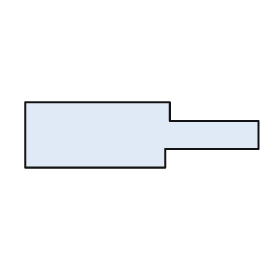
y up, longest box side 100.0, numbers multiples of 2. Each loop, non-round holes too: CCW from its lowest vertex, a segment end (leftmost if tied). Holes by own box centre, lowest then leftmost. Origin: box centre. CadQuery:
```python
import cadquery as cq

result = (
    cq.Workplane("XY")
    .moveTo(-50.0, -14.0)
    .lineTo(10.0, -14.0)
    .lineTo(10.0, -6.0)
    .lineTo(50.0, -6.0)
    .lineTo(50.0, 6.0)
    .lineTo(12.0, 6.0)
    .lineTo(12.0, 14.0)
    .lineTo(-50.0, 14.0)
    .close()
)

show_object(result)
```